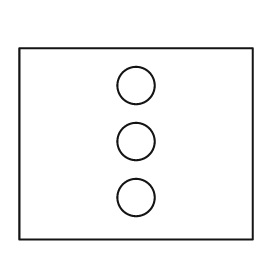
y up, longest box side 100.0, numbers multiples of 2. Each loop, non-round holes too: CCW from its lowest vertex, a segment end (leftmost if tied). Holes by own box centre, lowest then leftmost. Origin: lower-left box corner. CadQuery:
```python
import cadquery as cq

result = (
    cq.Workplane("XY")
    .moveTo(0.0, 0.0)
    .lineTo(100.0, 0.0)
    .lineTo(100.0, 82.0)
    .lineTo(0.0, 82.0)
    .close()
    .moveTo(50.0, 18.0)
    .circle(8.0)
    .moveTo(50.0, 42.0)
    .circle(8.0)
    .moveTo(50.0, 66.0)
    .circle(8.0)
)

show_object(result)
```